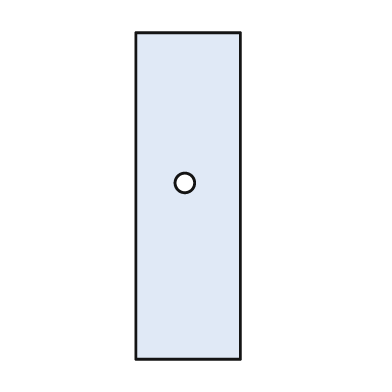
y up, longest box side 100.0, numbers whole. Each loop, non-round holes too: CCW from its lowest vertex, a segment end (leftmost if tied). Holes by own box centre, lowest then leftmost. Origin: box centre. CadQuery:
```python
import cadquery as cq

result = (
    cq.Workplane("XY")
    .moveTo(-16.0, -50.0)
    .lineTo(16.0, -50.0)
    .lineTo(16.0, 50.0)
    .lineTo(-16.0, 50.0)
    .close()
    .moveTo(-1.0, 4.0)
    .circle(3.0)
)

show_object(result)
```